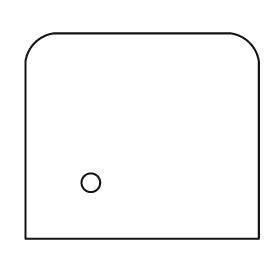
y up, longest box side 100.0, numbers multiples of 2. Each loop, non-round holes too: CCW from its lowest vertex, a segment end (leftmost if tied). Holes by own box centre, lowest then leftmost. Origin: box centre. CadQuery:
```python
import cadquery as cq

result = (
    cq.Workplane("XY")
    .moveTo(-50.0, -44.0)
    .lineTo(50.0, -44.0)
    .lineTo(50.0, 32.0)
    .threePointArc((46.0, 40.0), (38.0, 44.0))
    .lineTo(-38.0, 44.0)
    .threePointArc((-46.0, 40.0), (-50.0, 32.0))
    .close()
    .moveTo(-22.0, -20.0)
    .circle(4.0)
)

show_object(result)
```